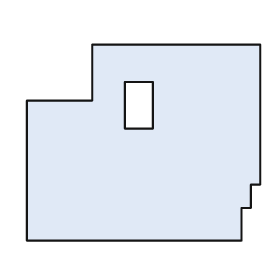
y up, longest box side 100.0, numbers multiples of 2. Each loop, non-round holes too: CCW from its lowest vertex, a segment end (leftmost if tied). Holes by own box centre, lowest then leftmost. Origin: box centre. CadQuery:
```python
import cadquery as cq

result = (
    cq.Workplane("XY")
    .moveTo(-50.0, -42.0)
    .lineTo(42.0, -42.0)
    .lineTo(42.0, -28.0)
    .lineTo(46.0, -28.0)
    .lineTo(46.0, -18.0)
    .lineTo(50.0, -18.0)
    .lineTo(50.0, 42.0)
    .lineTo(-22.0, 42.0)
    .lineTo(-22.0, 18.0)
    .lineTo(-50.0, 18.0)
    .close()
    .moveTo(-8.0, 6.0)
    .lineTo(4.0, 6.0)
    .lineTo(4.0, 26.0)
    .lineTo(-8.0, 26.0)
    .close()
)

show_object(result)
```